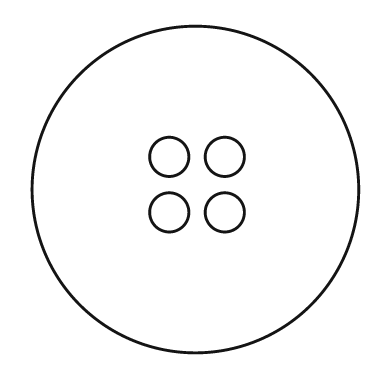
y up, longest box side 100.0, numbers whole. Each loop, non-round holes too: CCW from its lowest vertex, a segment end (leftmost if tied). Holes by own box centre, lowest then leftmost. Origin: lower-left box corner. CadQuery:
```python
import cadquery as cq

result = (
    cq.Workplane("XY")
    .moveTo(50.0, 50.0)
    .circle(50.0)
    .moveTo(42.0, 43.0)
    .circle(6.0)
    .moveTo(59.0, 43.0)
    .circle(6.0)
    .moveTo(42.0, 60.0)
    .circle(6.0)
    .moveTo(59.0, 60.0)
    .circle(6.0)
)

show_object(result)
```